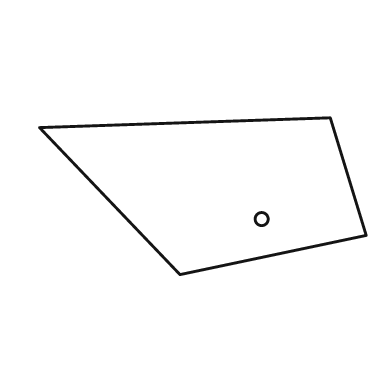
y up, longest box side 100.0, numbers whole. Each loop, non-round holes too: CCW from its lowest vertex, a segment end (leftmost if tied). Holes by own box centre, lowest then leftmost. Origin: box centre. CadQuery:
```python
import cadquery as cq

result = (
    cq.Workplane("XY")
    .moveTo(-7.0, -24.0)
    .lineTo(50.0, -12.0)
    .lineTo(39.0, 24.0)
    .lineTo(-50.0, 21.0)
    .close()
    .moveTo(18.0, -7.0)
    .circle(2.0)
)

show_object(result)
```